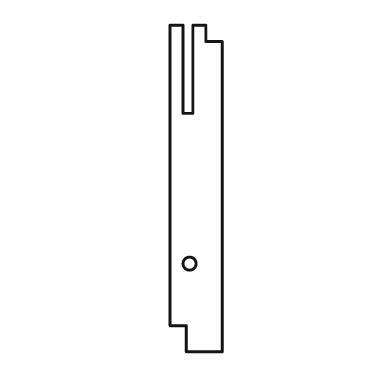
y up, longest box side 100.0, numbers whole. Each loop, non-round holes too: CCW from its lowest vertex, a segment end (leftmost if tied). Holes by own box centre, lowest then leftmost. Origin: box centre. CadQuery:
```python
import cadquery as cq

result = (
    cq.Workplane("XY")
    .moveTo(-3.0, -50.0)
    .lineTo(8.0, -50.0)
    .lineTo(8.0, 45.0)
    .lineTo(3.0, 45.0)
    .lineTo(3.0, 50.0)
    .lineTo(-1.0, 50.0)
    .lineTo(-1.0, 23.0)
    .lineTo(-4.0, 23.0)
    .lineTo(-4.0, 50.0)
    .lineTo(-8.0, 50.0)
    .lineTo(-8.0, -42.0)
    .lineTo(-3.0, -42.0)
    .close()
    .moveTo(-2.0, -23.0)
    .circle(2.0)
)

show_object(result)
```